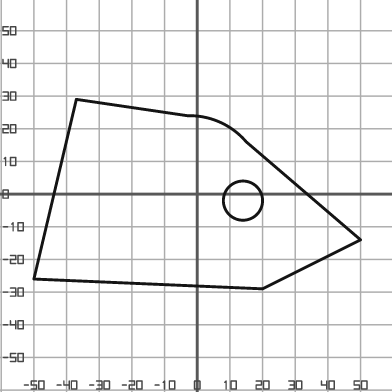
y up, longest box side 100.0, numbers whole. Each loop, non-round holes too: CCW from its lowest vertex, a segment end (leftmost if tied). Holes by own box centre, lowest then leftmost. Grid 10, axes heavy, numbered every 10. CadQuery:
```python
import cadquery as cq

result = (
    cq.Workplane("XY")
    .moveTo(20.0, -29.0)
    .lineTo(50.0, -14.0)
    .lineTo(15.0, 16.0)
    .threePointArc((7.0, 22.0), (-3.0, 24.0))
    .lineTo(-37.0, 29.0)
    .lineTo(-50.0, -26.0)
    .close()
    .moveTo(14.0, -2.0)
    .circle(6.0)
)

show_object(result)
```